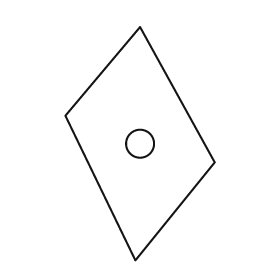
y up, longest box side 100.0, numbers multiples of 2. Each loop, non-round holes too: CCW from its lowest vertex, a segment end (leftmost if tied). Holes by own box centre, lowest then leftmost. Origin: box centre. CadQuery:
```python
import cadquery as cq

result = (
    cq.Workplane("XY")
    .moveTo(-2.0, -50.0)
    .lineTo(32.0, -8.0)
    .lineTo(0.0, 50.0)
    .lineTo(-32.0, 12.0)
    .close()
    .moveTo(0.0, 0.0)
    .circle(6.0)
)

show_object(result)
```